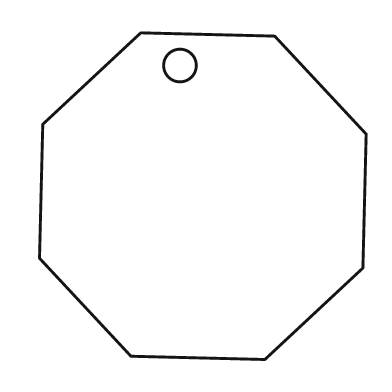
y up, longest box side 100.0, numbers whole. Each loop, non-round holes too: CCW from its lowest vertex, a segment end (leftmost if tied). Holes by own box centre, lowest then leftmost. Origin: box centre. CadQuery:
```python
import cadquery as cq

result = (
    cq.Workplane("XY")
    .moveTo(19.0, -50.0)
    .lineTo(49.0, -22.0)
    .lineTo(50.0, 19.0)
    .lineTo(22.0, 49.0)
    .lineTo(-19.0, 50.0)
    .lineTo(-49.0, 22.0)
    .lineTo(-50.0, -19.0)
    .lineTo(-22.0, -49.0)
    .close()
    .moveTo(-7.0, 40.0)
    .circle(5.0)
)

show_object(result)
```